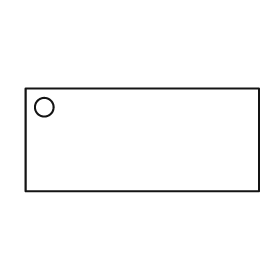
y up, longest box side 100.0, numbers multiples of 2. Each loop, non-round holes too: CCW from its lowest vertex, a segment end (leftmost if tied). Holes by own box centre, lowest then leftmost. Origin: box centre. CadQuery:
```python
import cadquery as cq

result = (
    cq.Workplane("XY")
    .moveTo(-50.0, -22.0)
    .lineTo(50.0, -22.0)
    .lineTo(50.0, 22.0)
    .lineTo(-50.0, 22.0)
    .close()
    .moveTo(-42.0, 14.0)
    .circle(4.0)
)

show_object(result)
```